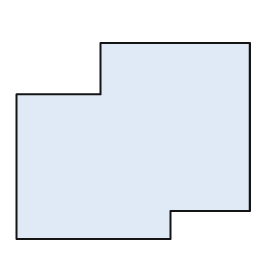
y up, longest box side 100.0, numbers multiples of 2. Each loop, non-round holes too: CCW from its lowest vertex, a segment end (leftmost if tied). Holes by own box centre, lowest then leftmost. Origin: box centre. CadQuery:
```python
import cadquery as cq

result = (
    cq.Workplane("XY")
    .moveTo(-50.0, -42.0)
    .lineTo(16.0, -42.0)
    .lineTo(16.0, -30.0)
    .lineTo(50.0, -30.0)
    .lineTo(50.0, 42.0)
    .lineTo(-14.0, 42.0)
    .lineTo(-14.0, 20.0)
    .lineTo(-50.0, 20.0)
    .close()
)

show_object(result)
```